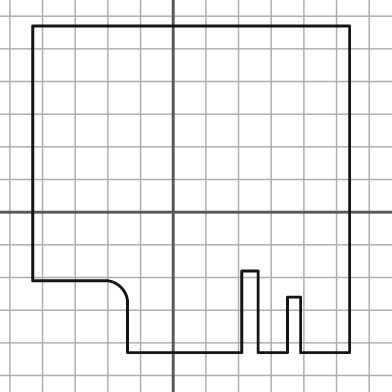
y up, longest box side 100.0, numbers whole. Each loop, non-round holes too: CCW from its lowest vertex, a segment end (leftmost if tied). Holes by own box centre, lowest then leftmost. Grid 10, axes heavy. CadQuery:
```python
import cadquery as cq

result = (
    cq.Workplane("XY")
    .moveTo(-14.0, -43.0)
    .lineTo(21.0, -43.0)
    .lineTo(21.0, -18.0)
    .lineTo(26.0, -18.0)
    .lineTo(26.0, -43.0)
    .lineTo(35.0, -43.0)
    .lineTo(35.0, -26.0)
    .lineTo(39.0, -26.0)
    .lineTo(39.0, -43.0)
    .lineTo(54.0, -43.0)
    .lineTo(54.0, 57.0)
    .lineTo(-43.0, 57.0)
    .lineTo(-43.0, -21.0)
    .lineTo(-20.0, -21.0)
    .threePointArc((-16.0, -23.0), (-14.0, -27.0))
    .close()
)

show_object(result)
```